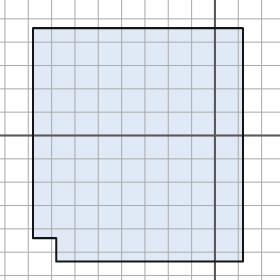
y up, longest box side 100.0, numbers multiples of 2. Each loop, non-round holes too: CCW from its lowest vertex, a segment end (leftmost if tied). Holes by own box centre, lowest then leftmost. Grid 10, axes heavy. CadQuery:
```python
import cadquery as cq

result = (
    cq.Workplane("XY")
    .moveTo(-68.0, -54.0)
    .lineTo(12.0, -54.0)
    .lineTo(12.0, 46.0)
    .lineTo(-78.0, 46.0)
    .lineTo(-78.0, -44.0)
    .lineTo(-68.0, -44.0)
    .close()
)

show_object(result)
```